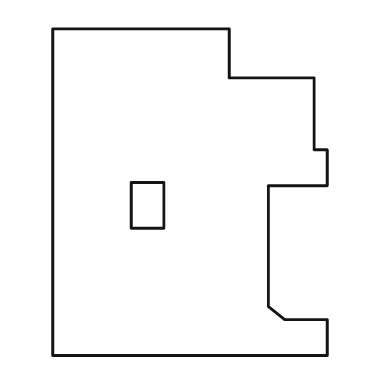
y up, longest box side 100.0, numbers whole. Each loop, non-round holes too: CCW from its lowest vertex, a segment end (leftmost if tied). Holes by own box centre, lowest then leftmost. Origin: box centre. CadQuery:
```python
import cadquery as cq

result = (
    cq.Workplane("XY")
    .moveTo(-42.0, -50.0)
    .lineTo(42.0, -50.0)
    .lineTo(42.0, -39.0)
    .lineTo(29.0, -39.0)
    .lineTo(24.0, -35.0)
    .lineTo(24.0, 2.0)
    .lineTo(42.0, 2.0)
    .lineTo(42.0, 13.0)
    .lineTo(38.0, 13.0)
    .lineTo(38.0, 35.0)
    .lineTo(12.0, 35.0)
    .lineTo(12.0, 50.0)
    .lineTo(-42.0, 50.0)
    .close()
    .moveTo(-18.0, -11.0)
    .lineTo(-8.0, -11.0)
    .lineTo(-8.0, 3.0)
    .lineTo(-18.0, 3.0)
    .close()
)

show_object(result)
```